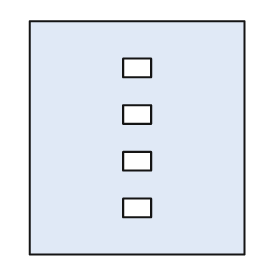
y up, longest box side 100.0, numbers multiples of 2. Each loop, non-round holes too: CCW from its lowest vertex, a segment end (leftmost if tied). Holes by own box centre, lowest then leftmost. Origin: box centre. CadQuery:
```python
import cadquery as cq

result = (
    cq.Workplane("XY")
    .moveTo(-46.0, -50.0)
    .lineTo(46.0, -50.0)
    .lineTo(46.0, 50.0)
    .lineTo(-46.0, 50.0)
    .close()
    .moveTo(-6.0, -34.0)
    .lineTo(6.0, -34.0)
    .lineTo(6.0, -26.0)
    .lineTo(-6.0, -26.0)
    .close()
    .moveTo(-6.0, -14.0)
    .lineTo(6.0, -14.0)
    .lineTo(6.0, -6.0)
    .lineTo(-6.0, -6.0)
    .close()
    .moveTo(-6.0, 6.0)
    .lineTo(6.0, 6.0)
    .lineTo(6.0, 14.0)
    .lineTo(-6.0, 14.0)
    .close()
    .moveTo(-6.0, 26.0)
    .lineTo(6.0, 26.0)
    .lineTo(6.0, 34.0)
    .lineTo(-6.0, 34.0)
    .close()
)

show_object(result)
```